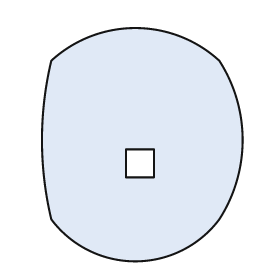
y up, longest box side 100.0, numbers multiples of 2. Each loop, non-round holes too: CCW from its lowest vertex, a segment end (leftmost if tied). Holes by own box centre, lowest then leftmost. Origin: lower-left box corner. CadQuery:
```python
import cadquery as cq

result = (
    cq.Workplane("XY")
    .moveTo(4.0, 18.0)
    .threePointArc((40.0, 0.0), (76.0, 18.0))
    .threePointArc((86.0, 52.0), (76.0, 86.0))
    .threePointArc((40.0, 100.0), (4.0, 86.0))
    .threePointArc((0.0, 52.0), (4.0, 18.0))
    .close()
    .moveTo(36.0, 36.0)
    .lineTo(48.0, 36.0)
    .lineTo(48.0, 48.0)
    .lineTo(36.0, 48.0)
    .close()
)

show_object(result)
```